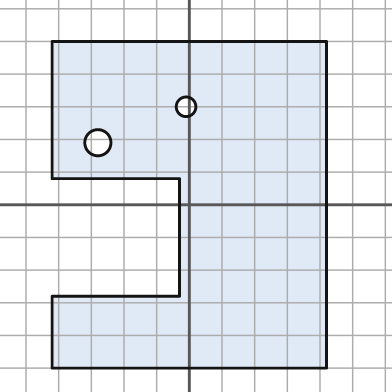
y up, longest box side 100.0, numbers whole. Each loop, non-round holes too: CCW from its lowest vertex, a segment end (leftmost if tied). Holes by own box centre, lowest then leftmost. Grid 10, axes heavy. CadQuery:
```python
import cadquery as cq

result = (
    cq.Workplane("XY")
    .moveTo(-42.0, -50.0)
    .lineTo(42.0, -50.0)
    .lineTo(42.0, 50.0)
    .lineTo(-42.0, 50.0)
    .lineTo(-42.0, 8.0)
    .lineTo(-3.0, 8.0)
    .lineTo(-3.0, -28.0)
    .lineTo(-42.0, -28.0)
    .close()
    .moveTo(-28.0, 19.0)
    .circle(4.0)
    .moveTo(-1.0, 30.0)
    .circle(3.0)
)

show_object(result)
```